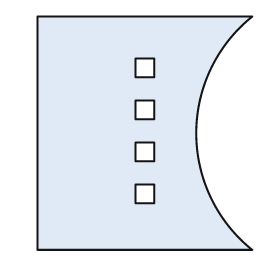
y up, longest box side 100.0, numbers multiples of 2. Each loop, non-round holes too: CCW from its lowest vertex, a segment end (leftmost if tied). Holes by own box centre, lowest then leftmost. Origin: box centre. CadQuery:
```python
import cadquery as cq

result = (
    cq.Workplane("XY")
    .moveTo(-46.0, -50.0)
    .lineTo(46.0, -50.0)
    .threePointArc((22.0, 0.0), (46.0, 50.0))
    .lineTo(-46.0, 50.0)
    .close()
    .moveTo(-4.0, -30.0)
    .lineTo(4.0, -30.0)
    .lineTo(4.0, -22.0)
    .lineTo(-4.0, -22.0)
    .close()
    .moveTo(-4.0, -12.0)
    .lineTo(4.0, -12.0)
    .lineTo(4.0, -4.0)
    .lineTo(-4.0, -4.0)
    .close()
    .moveTo(-4.0, 6.0)
    .lineTo(4.0, 6.0)
    .lineTo(4.0, 14.0)
    .lineTo(-4.0, 14.0)
    .close()
    .moveTo(-4.0, 24.0)
    .lineTo(4.0, 24.0)
    .lineTo(4.0, 32.0)
    .lineTo(-4.0, 32.0)
    .close()
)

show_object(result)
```